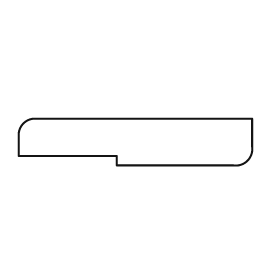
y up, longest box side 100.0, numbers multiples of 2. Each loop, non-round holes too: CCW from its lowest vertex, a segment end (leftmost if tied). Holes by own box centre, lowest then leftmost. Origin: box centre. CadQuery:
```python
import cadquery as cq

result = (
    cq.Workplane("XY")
    .moveTo(-8.0, -10.0)
    .lineTo(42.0, -10.0)
    .threePointArc((48.0, -8.0), (50.0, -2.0))
    .lineTo(50.0, 10.0)
    .lineTo(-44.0, 10.0)
    .threePointArc((-48.0, 8.0), (-50.0, 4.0))
    .lineTo(-50.0, -6.0)
    .lineTo(-8.0, -6.0)
    .close()
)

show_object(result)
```